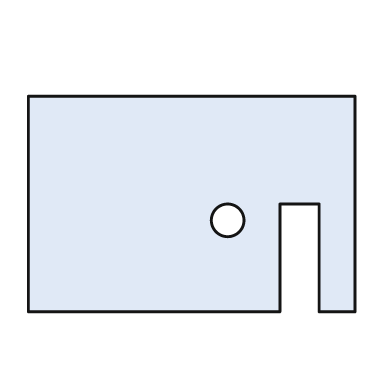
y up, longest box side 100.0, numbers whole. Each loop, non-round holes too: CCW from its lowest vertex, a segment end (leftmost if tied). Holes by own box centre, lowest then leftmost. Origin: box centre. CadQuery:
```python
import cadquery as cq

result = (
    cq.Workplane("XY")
    .moveTo(-50.0, -33.0)
    .lineTo(27.0, -33.0)
    .lineTo(27.0, 0.0)
    .lineTo(39.0, 0.0)
    .lineTo(39.0, -33.0)
    .lineTo(50.0, -33.0)
    .lineTo(50.0, 33.0)
    .lineTo(-50.0, 33.0)
    .close()
    .moveTo(11.0, -5.0)
    .circle(5.0)
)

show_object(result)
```